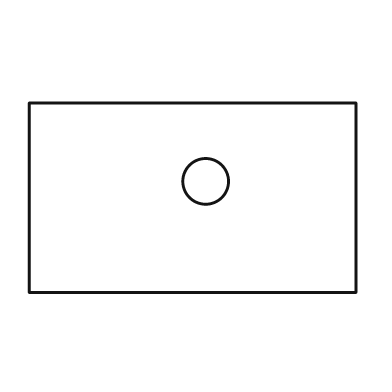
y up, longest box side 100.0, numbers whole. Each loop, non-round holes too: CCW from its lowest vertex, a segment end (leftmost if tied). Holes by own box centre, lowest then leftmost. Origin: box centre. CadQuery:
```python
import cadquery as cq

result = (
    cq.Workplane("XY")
    .moveTo(-50.0, -29.0)
    .lineTo(50.0, -29.0)
    .lineTo(50.0, 29.0)
    .lineTo(-50.0, 29.0)
    .close()
    .moveTo(4.0, 5.0)
    .circle(7.0)
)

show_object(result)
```